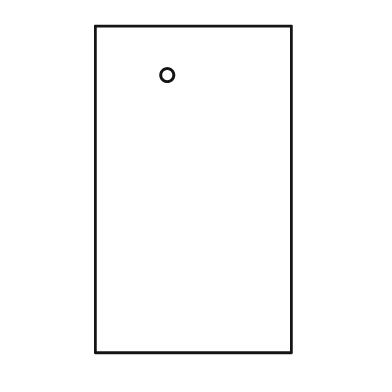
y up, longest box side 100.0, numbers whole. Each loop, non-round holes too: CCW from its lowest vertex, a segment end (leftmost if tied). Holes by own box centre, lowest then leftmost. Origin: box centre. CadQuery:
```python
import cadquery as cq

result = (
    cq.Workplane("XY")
    .moveTo(-30.0, -50.0)
    .lineTo(30.0, -50.0)
    .lineTo(30.0, 50.0)
    .lineTo(-30.0, 50.0)
    .close()
    .moveTo(-8.0, 35.0)
    .circle(2.0)
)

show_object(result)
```